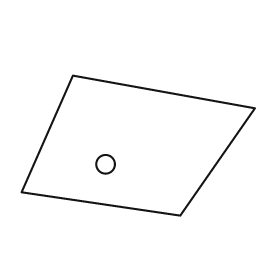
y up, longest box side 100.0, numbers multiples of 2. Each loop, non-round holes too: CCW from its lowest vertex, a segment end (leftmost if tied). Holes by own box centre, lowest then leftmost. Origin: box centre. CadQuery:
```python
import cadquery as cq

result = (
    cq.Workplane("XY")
    .moveTo(18.0, -30.0)
    .lineTo(50.0, 16.0)
    .lineTo(-28.0, 30.0)
    .lineTo(-50.0, -20.0)
    .close()
    .moveTo(-14.0, -8.0)
    .circle(4.0)
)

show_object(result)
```